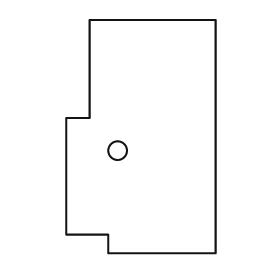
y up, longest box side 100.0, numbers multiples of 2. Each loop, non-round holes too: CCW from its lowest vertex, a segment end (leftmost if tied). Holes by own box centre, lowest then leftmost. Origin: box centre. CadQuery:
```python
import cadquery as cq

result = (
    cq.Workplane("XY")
    .moveTo(-14.0, -50.0)
    .lineTo(32.0, -50.0)
    .lineTo(32.0, 50.0)
    .lineTo(-22.0, 50.0)
    .lineTo(-22.0, 8.0)
    .lineTo(-32.0, 8.0)
    .lineTo(-32.0, -42.0)
    .lineTo(-14.0, -42.0)
    .close()
    .moveTo(-10.0, -6.0)
    .circle(4.0)
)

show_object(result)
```